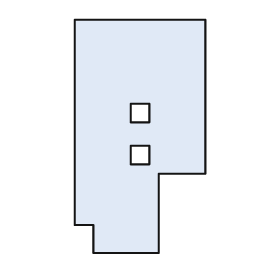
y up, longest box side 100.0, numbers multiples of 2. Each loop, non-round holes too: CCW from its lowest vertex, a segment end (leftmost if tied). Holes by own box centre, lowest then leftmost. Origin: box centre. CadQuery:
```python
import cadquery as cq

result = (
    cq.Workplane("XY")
    .moveTo(-20.0, -50.0)
    .lineTo(8.0, -50.0)
    .lineTo(8.0, -16.0)
    .lineTo(28.0, -16.0)
    .lineTo(28.0, 50.0)
    .lineTo(-28.0, 50.0)
    .lineTo(-28.0, -38.0)
    .lineTo(-20.0, -38.0)
    .close()
    .moveTo(-4.0, -12.0)
    .lineTo(4.0, -12.0)
    .lineTo(4.0, -4.0)
    .lineTo(-4.0, -4.0)
    .close()
    .moveTo(-4.0, 6.0)
    .lineTo(4.0, 6.0)
    .lineTo(4.0, 14.0)
    .lineTo(-4.0, 14.0)
    .close()
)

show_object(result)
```